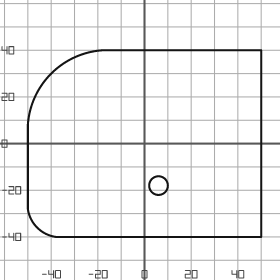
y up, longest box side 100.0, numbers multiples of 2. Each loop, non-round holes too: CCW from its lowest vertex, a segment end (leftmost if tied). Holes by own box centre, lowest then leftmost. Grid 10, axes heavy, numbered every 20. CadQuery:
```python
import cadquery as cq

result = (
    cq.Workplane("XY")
    .moveTo(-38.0, -40.0)
    .lineTo(50.0, -40.0)
    .lineTo(50.0, 40.0)
    .lineTo(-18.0, 40.0)
    .threePointArc((-40.0, 30.0), (-50.0, 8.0))
    .lineTo(-50.0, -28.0)
    .threePointArc((-46.0, -36.0), (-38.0, -40.0))
    .close()
    .moveTo(6.0, -18.0)
    .circle(4.0)
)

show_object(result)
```